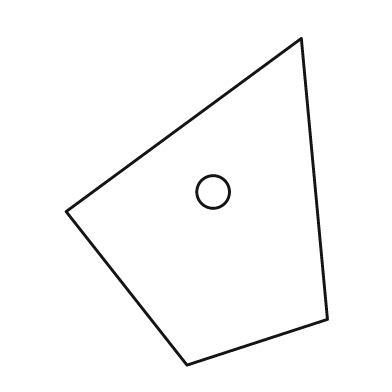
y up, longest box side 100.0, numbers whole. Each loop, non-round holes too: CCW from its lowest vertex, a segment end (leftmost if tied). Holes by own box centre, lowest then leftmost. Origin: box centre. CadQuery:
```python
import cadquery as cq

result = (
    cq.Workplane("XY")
    .moveTo(-3.0, -50.0)
    .lineTo(40.0, -36.0)
    .lineTo(32.0, 50.0)
    .lineTo(-40.0, -3.0)
    .close()
    .moveTo(5.0, 3.0)
    .circle(5.0)
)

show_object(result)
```